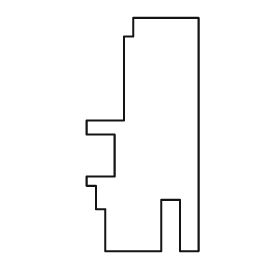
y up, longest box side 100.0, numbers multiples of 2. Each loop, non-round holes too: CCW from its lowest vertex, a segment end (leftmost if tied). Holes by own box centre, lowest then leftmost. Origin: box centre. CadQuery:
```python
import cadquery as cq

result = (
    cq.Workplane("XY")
    .moveTo(-16.0, -50.0)
    .lineTo(8.0, -50.0)
    .lineTo(8.0, -28.0)
    .lineTo(16.0, -28.0)
    .lineTo(16.0, -50.0)
    .lineTo(24.0, -50.0)
    .lineTo(24.0, 50.0)
    .lineTo(-4.0, 50.0)
    .lineTo(-4.0, 42.0)
    .lineTo(-8.0, 42.0)
    .lineTo(-8.0, 6.0)
    .lineTo(-24.0, 6.0)
    .lineTo(-24.0, 0.0)
    .lineTo(-12.0, 0.0)
    .lineTo(-12.0, -18.0)
    .lineTo(-24.0, -18.0)
    .lineTo(-24.0, -22.0)
    .lineTo(-20.0, -22.0)
    .lineTo(-20.0, -32.0)
    .lineTo(-16.0, -32.0)
    .close()
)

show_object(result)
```